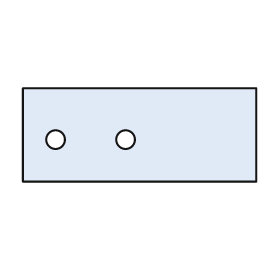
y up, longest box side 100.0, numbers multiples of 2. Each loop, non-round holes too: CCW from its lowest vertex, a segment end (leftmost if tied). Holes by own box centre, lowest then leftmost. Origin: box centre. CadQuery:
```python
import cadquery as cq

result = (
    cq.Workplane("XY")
    .moveTo(-50.0, -20.0)
    .lineTo(50.0, -20.0)
    .lineTo(50.0, 20.0)
    .lineTo(-50.0, 20.0)
    .close()
    .moveTo(-36.0, -2.0)
    .circle(4.0)
    .moveTo(-6.0, -2.0)
    .circle(4.0)
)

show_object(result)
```